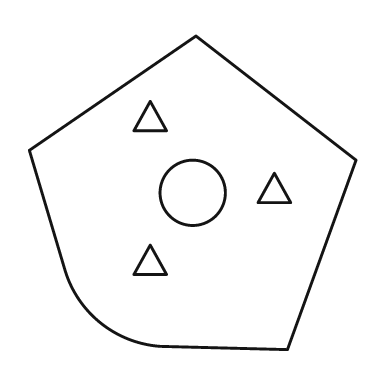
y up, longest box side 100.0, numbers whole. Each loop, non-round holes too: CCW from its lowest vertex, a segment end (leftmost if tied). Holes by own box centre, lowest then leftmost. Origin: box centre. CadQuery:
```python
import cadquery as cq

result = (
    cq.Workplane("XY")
    .moveTo(29.0, -48.0)
    .lineTo(50.0, 10.0)
    .lineTo(1.0, 48.0)
    .lineTo(-50.0, 13.0)
    .lineTo(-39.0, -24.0)
    .threePointArc((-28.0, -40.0), (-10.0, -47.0))
    .close()
    .moveTo(-18.0, -25.0)
    .lineTo(-8.0, -25.0)
    .lineTo(-13.0, -16.0)
    .close()
    .moveTo(0.0, 0.0)
    .circle(10.0)
    .moveTo(20.0, -3.0)
    .lineTo(30.0, -3.0)
    .lineTo(25.0, 6.0)
    .close()
    .moveTo(-18.0, 19.0)
    .lineTo(-8.0, 19.0)
    .lineTo(-13.0, 28.0)
    .close()
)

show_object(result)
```